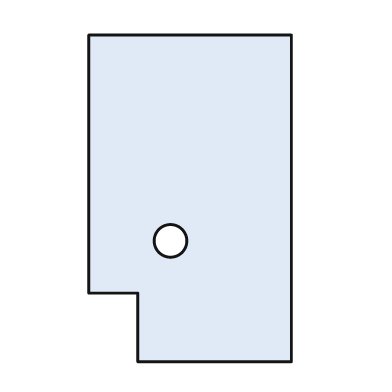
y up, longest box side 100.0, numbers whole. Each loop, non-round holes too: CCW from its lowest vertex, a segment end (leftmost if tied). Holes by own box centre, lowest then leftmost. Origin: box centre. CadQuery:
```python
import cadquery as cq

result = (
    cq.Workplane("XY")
    .moveTo(-16.0, -50.0)
    .lineTo(31.0, -50.0)
    .lineTo(31.0, 50.0)
    .lineTo(-31.0, 50.0)
    .lineTo(-31.0, -29.0)
    .lineTo(-16.0, -29.0)
    .close()
    .moveTo(-6.0, -13.0)
    .circle(5.0)
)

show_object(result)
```